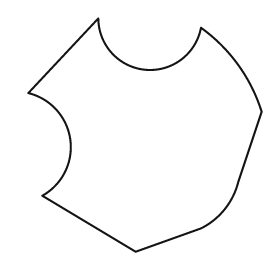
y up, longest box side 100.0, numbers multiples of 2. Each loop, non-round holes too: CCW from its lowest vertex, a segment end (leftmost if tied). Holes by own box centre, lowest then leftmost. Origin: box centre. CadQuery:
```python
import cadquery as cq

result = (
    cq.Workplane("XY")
    .moveTo(-4.0, -50.0)
    .lineTo(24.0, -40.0)
    .threePointArc((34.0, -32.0), (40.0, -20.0))
    .lineTo(50.0, 10.0)
    .threePointArc((40.0, 30.0), (24.0, 46.0))
    .threePointArc((0.0, 28.0), (-20.0, 50.0))
    .lineTo(-50.0, 18.0)
    .threePointArc((-32.0, -2.0), (-44.0, -26.0))
    .close()
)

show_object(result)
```